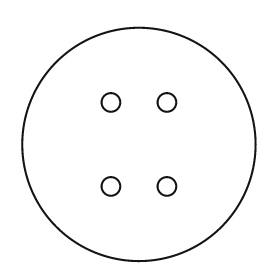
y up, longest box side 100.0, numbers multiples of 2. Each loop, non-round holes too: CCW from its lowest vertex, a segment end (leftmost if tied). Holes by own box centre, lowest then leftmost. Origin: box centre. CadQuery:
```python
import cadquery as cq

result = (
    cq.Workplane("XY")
    .moveTo(0.0, 0.0)
    .circle(50.0)
    .moveTo(-12.0, -18.0)
    .circle(4.0)
    .moveTo(12.0, -18.0)
    .circle(4.0)
    .moveTo(-12.0, 18.0)
    .circle(4.0)
    .moveTo(12.0, 18.0)
    .circle(4.0)
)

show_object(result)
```